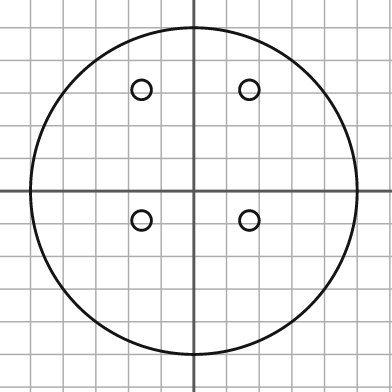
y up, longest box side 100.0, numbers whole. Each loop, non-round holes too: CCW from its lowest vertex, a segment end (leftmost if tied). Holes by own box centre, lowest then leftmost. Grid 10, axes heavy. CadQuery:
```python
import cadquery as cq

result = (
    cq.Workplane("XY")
    .moveTo(0.0, 0.0)
    .circle(50.0)
    .moveTo(-16.0, -9.0)
    .circle(3.0)
    .moveTo(17.0, -9.0)
    .circle(3.0)
    .moveTo(-16.0, 31.0)
    .circle(3.0)
    .moveTo(17.0, 31.0)
    .circle(3.0)
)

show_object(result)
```